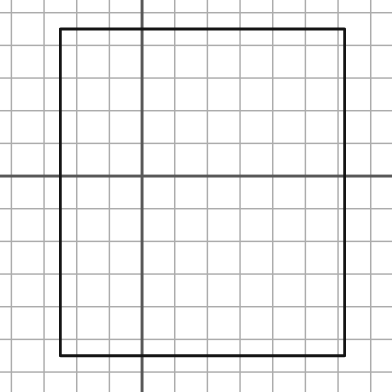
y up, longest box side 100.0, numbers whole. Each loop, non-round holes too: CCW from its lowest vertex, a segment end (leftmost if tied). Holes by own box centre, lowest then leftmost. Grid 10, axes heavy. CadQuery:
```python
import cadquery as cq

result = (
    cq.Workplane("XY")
    .moveTo(-25.0, -55.0)
    .lineTo(62.0, -55.0)
    .lineTo(62.0, 45.0)
    .lineTo(-25.0, 45.0)
    .close()
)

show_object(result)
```